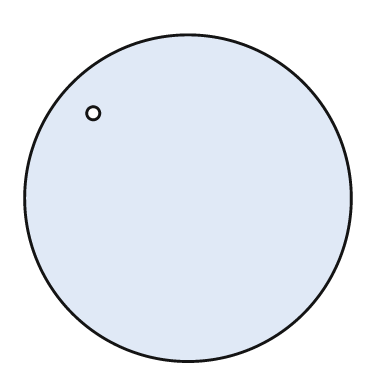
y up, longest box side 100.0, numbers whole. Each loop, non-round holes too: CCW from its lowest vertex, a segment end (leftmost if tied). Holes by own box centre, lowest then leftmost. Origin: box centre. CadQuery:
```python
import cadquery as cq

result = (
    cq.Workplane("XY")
    .moveTo(0.0, 0.0)
    .circle(50.0)
    .moveTo(-29.0, 26.0)
    .circle(2.0)
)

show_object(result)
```